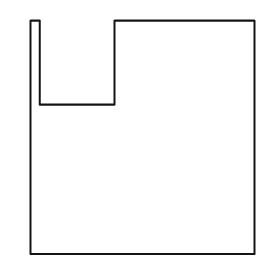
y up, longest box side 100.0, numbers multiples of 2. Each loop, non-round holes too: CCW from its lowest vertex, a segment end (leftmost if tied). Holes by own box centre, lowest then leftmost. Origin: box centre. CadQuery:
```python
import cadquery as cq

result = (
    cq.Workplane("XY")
    .moveTo(-48.0, -50.0)
    .lineTo(48.0, -50.0)
    .lineTo(48.0, 50.0)
    .lineTo(-12.0, 50.0)
    .lineTo(-12.0, 14.0)
    .lineTo(-44.0, 14.0)
    .lineTo(-44.0, 50.0)
    .lineTo(-48.0, 50.0)
    .close()
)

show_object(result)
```